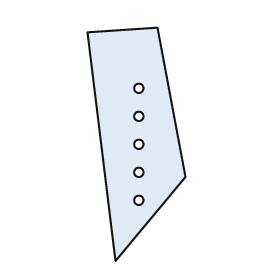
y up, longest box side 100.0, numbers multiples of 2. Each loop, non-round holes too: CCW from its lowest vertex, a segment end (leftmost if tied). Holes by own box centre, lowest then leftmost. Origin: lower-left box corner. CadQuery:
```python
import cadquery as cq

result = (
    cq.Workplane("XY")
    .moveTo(12.0, 0.0)
    .lineTo(42.0, 36.0)
    .lineTo(30.0, 100.0)
    .lineTo(0.0, 98.0)
    .close()
    .moveTo(22.0, 26.0)
    .circle(2.0)
    .moveTo(22.0, 38.0)
    .circle(2.0)
    .moveTo(22.0, 50.0)
    .circle(2.0)
    .moveTo(22.0, 62.0)
    .circle(2.0)
    .moveTo(22.0, 74.0)
    .circle(2.0)
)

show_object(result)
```